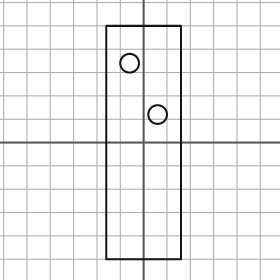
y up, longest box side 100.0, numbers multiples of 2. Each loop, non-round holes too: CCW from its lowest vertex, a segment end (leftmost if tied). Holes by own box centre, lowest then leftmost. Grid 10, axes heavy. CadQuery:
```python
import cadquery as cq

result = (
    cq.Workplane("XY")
    .moveTo(-16.0, -50.0)
    .lineTo(16.0, -50.0)
    .lineTo(16.0, 50.0)
    .lineTo(-16.0, 50.0)
    .close()
    .moveTo(6.0, 12.0)
    .circle(4.0)
    .moveTo(-6.0, 34.0)
    .circle(4.0)
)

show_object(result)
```